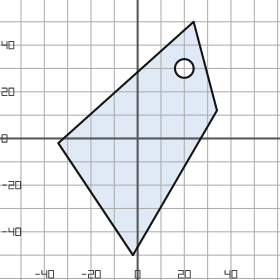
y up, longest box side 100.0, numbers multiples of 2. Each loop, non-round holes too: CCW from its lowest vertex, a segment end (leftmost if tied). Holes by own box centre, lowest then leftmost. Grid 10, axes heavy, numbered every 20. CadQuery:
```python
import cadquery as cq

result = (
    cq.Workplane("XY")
    .moveTo(-2.0, -50.0)
    .lineTo(34.0, 12.0)
    .lineTo(24.0, 50.0)
    .lineTo(-34.0, -2.0)
    .close()
    .moveTo(20.0, 30.0)
    .circle(4.0)
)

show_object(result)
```